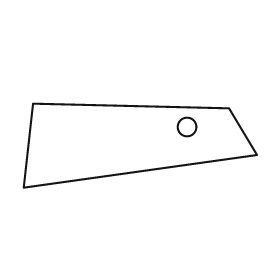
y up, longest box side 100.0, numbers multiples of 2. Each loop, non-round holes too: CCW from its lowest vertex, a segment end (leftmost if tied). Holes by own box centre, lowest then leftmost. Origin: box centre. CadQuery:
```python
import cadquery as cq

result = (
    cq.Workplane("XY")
    .moveTo(-50.0, -18.0)
    .lineTo(50.0, -4.0)
    .lineTo(38.0, 16.0)
    .lineTo(-46.0, 18.0)
    .close()
    .moveTo(20.0, 8.0)
    .circle(4.0)
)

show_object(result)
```